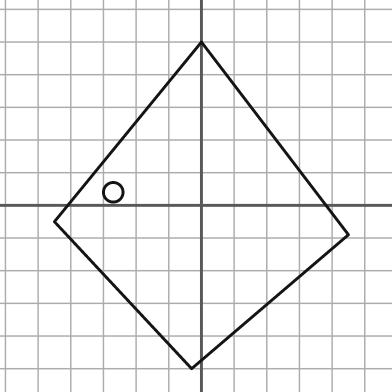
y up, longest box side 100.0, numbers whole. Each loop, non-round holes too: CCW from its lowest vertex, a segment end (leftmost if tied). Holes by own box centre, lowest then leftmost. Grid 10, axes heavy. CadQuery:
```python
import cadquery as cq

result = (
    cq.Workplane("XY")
    .moveTo(-3.0, -50.0)
    .lineTo(45.0, -9.0)
    .lineTo(0.0, 50.0)
    .lineTo(-45.0, -5.0)
    .close()
    .moveTo(-27.0, 4.0)
    .circle(3.0)
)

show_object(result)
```